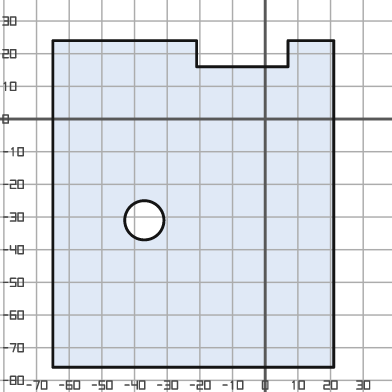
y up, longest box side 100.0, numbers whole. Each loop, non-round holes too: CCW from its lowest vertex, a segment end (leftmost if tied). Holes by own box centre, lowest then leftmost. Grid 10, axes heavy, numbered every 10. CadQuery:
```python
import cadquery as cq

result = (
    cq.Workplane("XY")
    .moveTo(-65.0, -76.0)
    .lineTo(21.0, -76.0)
    .lineTo(21.0, 24.0)
    .lineTo(7.0, 24.0)
    .lineTo(7.0, 16.0)
    .lineTo(-21.0, 16.0)
    .lineTo(-21.0, 24.0)
    .lineTo(-65.0, 24.0)
    .close()
    .moveTo(-37.0, -31.0)
    .circle(6.0)
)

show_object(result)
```